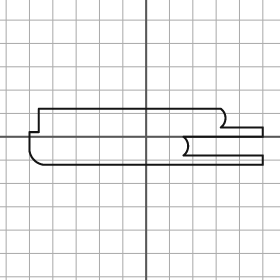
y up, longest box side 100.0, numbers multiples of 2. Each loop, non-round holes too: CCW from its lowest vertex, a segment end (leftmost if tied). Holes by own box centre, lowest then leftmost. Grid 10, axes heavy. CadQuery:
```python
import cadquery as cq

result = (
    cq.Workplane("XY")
    .moveTo(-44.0, -12.0)
    .lineTo(50.0, -12.0)
    .lineTo(50.0, -8.0)
    .lineTo(16.0, -8.0)
    .threePointArc((18.0, -4.0), (16.0, 0.0))
    .lineTo(50.0, 0.0)
    .lineTo(50.0, 4.0)
    .lineTo(32.0, 4.0)
    .threePointArc((34.0, 8.0), (32.0, 12.0))
    .lineTo(-46.0, 12.0)
    .lineTo(-46.0, 2.0)
    .lineTo(-50.0, 2.0)
    .lineTo(-50.0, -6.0)
    .threePointArc((-48.0, -10.0), (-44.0, -12.0))
    .close()
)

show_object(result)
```